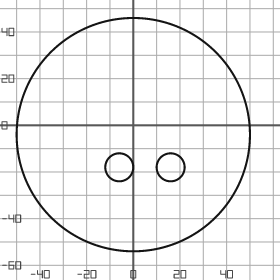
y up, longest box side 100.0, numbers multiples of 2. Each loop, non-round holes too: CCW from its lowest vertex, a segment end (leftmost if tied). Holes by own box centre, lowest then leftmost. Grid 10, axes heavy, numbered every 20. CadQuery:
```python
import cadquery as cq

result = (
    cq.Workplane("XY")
    .moveTo(0.0, -4.0)
    .circle(50.0)
    .moveTo(-6.0, -18.0)
    .circle(6.0)
    .moveTo(16.0, -18.0)
    .circle(6.0)
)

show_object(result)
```